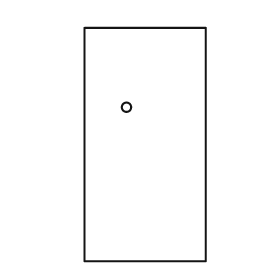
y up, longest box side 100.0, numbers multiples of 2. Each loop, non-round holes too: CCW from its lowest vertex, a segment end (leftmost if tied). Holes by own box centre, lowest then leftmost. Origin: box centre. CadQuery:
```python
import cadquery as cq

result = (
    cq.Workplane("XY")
    .moveTo(-26.0, -50.0)
    .lineTo(26.0, -50.0)
    .lineTo(26.0, 50.0)
    .lineTo(-26.0, 50.0)
    .close()
    .moveTo(-8.0, 16.0)
    .circle(2.0)
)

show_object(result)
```